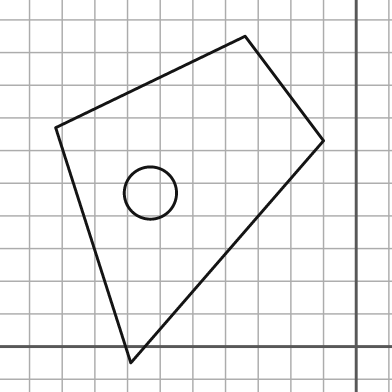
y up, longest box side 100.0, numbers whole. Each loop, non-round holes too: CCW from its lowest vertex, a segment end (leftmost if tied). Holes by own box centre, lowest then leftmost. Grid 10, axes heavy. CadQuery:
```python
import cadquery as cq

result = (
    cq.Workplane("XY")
    .moveTo(-69.0, -5.0)
    .lineTo(-10.0, 63.0)
    .lineTo(-34.0, 95.0)
    .lineTo(-92.0, 67.0)
    .close()
    .moveTo(-63.0, 47.0)
    .circle(8.0)
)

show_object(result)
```